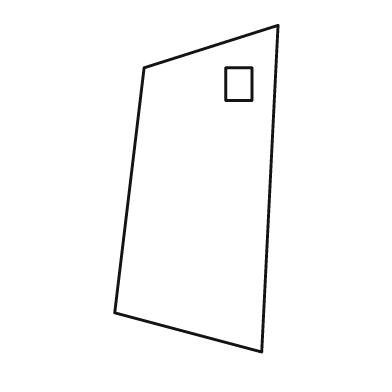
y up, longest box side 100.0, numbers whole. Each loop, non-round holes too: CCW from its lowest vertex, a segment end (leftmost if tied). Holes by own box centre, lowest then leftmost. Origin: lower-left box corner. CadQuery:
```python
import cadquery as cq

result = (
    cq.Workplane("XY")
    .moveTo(45.0, 0.0)
    .lineTo(50.0, 100.0)
    .lineTo(9.0, 87.0)
    .lineTo(0.0, 12.0)
    .close()
    .moveTo(34.0, 77.0)
    .lineTo(42.0, 77.0)
    .lineTo(42.0, 87.0)
    .lineTo(34.0, 87.0)
    .close()
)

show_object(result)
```